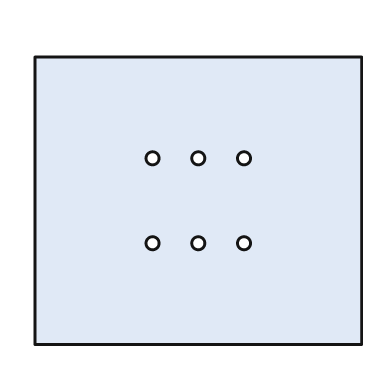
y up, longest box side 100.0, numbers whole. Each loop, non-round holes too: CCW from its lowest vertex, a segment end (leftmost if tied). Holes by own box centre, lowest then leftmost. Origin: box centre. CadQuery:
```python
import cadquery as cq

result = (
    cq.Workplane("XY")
    .moveTo(-50.0, -44.0)
    .lineTo(50.0, -44.0)
    .lineTo(50.0, 44.0)
    .lineTo(-50.0, 44.0)
    .close()
    .moveTo(-14.0, -13.0)
    .circle(2.0)
    .moveTo(0.0, -13.0)
    .circle(2.0)
    .moveTo(14.0, -13.0)
    .circle(2.0)
    .moveTo(-14.0, 13.0)
    .circle(2.0)
    .moveTo(0.0, 13.0)
    .circle(2.0)
    .moveTo(14.0, 13.0)
    .circle(2.0)
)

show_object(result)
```